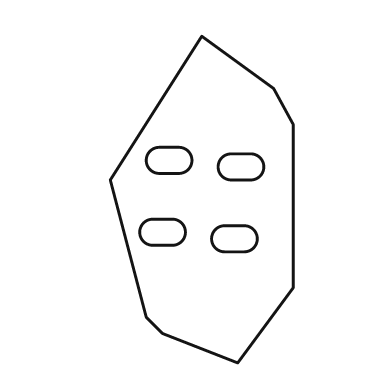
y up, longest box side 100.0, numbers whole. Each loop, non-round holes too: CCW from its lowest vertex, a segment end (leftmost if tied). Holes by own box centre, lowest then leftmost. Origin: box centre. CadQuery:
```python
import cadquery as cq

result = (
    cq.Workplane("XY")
    .moveTo(11.0, -50.0)
    .lineTo(28.0, -27.0)
    .lineTo(28.0, 23.0)
    .lineTo(22.0, 34.0)
    .lineTo(0.0, 50.0)
    .lineTo(-28.0, 6.0)
    .lineTo(-17.0, -36.0)
    .lineTo(-12.0, -41.0)
    .close()
    .moveTo(7.0, -16.0)
    .lineTo(13.0, -16.0)
    .threePointArc((17.0, -12.0), (13.0, -8.0))
    .lineTo(7.0, -8.0)
    .threePointArc((3.0, -12.0), (7.0, -16.0))
    .close()
    .moveTo(-15.0, -14.0)
    .lineTo(-9.0, -14.0)
    .threePointArc((-5.0, -10.0), (-9.0, -6.0))
    .lineTo(-15.0, -6.0)
    .threePointArc((-19.0, -10.0), (-15.0, -14.0))
    .close()
    .moveTo(9.0, 6.0)
    .lineTo(15.0, 6.0)
    .threePointArc((19.0, 10.0), (15.0, 14.0))
    .lineTo(9.0, 14.0)
    .threePointArc((5.0, 10.0), (9.0, 6.0))
    .close()
    .moveTo(-13.0, 8.0)
    .lineTo(-7.0, 8.0)
    .threePointArc((-3.0, 12.0), (-7.0, 16.0))
    .lineTo(-13.0, 16.0)
    .threePointArc((-17.0, 12.0), (-13.0, 8.0))
    .close()
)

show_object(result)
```